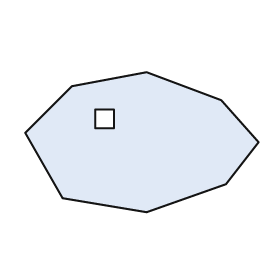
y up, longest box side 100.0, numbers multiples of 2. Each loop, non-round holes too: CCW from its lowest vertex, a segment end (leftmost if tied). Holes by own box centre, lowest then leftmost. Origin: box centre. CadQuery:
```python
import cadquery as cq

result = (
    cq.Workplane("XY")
    .moveTo(2.0, -30.0)
    .lineTo(36.0, -18.0)
    .lineTo(50.0, 0.0)
    .lineTo(34.0, 18.0)
    .lineTo(2.0, 30.0)
    .lineTo(-30.0, 24.0)
    .lineTo(-50.0, 4.0)
    .lineTo(-34.0, -24.0)
    .close()
    .moveTo(-20.0, 6.0)
    .lineTo(-12.0, 6.0)
    .lineTo(-12.0, 14.0)
    .lineTo(-20.0, 14.0)
    .close()
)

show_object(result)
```